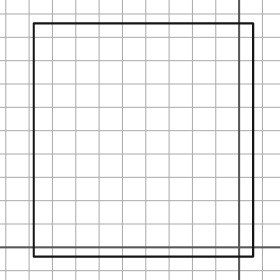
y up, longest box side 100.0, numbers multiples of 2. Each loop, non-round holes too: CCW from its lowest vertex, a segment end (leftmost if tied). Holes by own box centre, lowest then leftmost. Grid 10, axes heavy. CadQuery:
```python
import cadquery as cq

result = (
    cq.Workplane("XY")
    .moveTo(-88.0, -4.0)
    .lineTo(6.0, -4.0)
    .lineTo(6.0, 96.0)
    .lineTo(-88.0, 96.0)
    .close()
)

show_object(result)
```